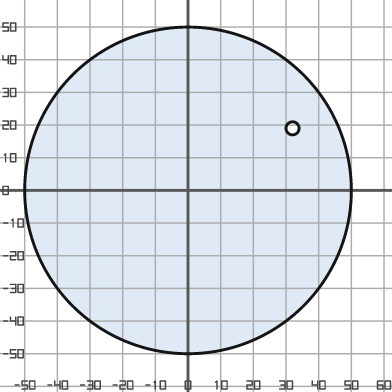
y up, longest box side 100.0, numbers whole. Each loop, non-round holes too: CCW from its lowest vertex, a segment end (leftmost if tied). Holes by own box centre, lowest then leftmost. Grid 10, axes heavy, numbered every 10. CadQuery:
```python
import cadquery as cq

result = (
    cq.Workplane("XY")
    .moveTo(0.0, 0.0)
    .circle(50.0)
    .moveTo(32.0, 19.0)
    .circle(2.0)
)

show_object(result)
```